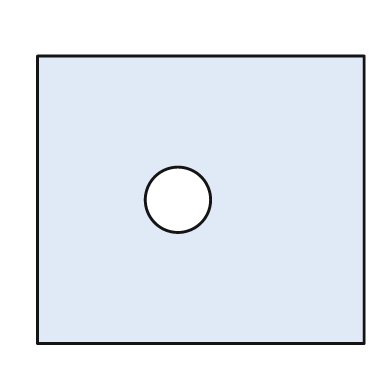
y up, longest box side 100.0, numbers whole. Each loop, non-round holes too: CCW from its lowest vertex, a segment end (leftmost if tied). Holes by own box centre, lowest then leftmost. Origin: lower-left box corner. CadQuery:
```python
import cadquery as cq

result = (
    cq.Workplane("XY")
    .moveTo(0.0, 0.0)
    .lineTo(100.0, 0.0)
    .lineTo(100.0, 88.0)
    .lineTo(0.0, 88.0)
    .close()
    .moveTo(43.0, 44.0)
    .circle(10.0)
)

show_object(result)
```